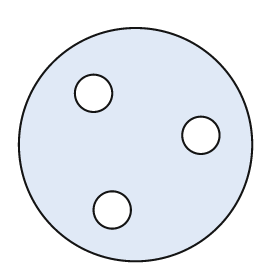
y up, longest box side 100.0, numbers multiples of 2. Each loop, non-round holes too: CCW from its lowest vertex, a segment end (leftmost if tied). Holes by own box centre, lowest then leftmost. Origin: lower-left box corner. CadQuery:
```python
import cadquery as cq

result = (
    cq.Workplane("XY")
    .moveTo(50.0, 50.0)
    .circle(50.0)
    .moveTo(40.0, 22.0)
    .circle(8.0)
    .moveTo(78.0, 54.0)
    .circle(8.0)
    .moveTo(32.0, 72.0)
    .circle(8.0)
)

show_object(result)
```